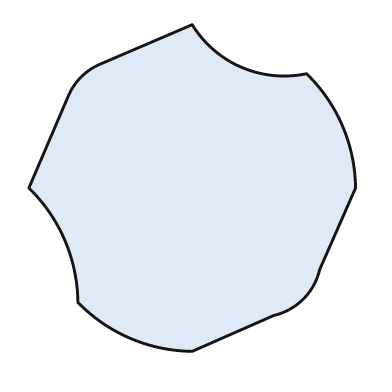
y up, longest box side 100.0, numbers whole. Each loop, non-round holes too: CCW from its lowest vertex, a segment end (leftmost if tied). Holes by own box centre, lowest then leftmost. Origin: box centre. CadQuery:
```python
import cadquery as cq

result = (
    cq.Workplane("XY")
    .moveTo(0.0, -50.0)
    .lineTo(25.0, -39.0)
    .threePointArc((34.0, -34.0), (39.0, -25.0))
    .lineTo(50.0, 0.0)
    .threePointArc((46.0, 19.0), (35.0, 35.0))
    .threePointArc((15.0, 37.0), (0.0, 50.0))
    .lineTo(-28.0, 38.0)
    .threePointArc((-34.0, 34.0), (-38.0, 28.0))
    .lineTo(-50.0, 0.0)
    .threePointArc((-39.0, -16.0), (-35.0, -35.0))
    .threePointArc((-19.0, -46.0), (0.0, -50.0))
    .close()
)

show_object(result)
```